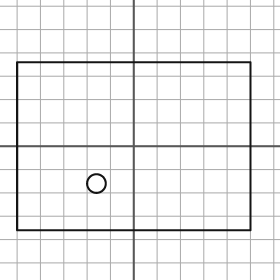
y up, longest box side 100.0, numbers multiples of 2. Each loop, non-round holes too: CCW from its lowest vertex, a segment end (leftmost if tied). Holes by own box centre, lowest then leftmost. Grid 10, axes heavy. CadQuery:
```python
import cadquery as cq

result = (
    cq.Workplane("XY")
    .moveTo(-50.0, -36.0)
    .lineTo(50.0, -36.0)
    .lineTo(50.0, 36.0)
    .lineTo(-50.0, 36.0)
    .close()
    .moveTo(-16.0, -16.0)
    .circle(4.0)
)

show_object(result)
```